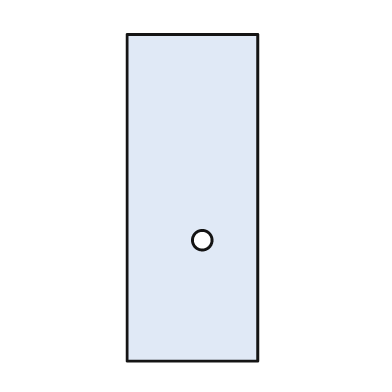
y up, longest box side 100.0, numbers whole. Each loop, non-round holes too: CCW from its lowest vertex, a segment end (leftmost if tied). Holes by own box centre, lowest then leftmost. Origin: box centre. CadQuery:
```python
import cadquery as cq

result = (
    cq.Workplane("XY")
    .moveTo(-20.0, -50.0)
    .lineTo(20.0, -50.0)
    .lineTo(20.0, 50.0)
    .lineTo(-20.0, 50.0)
    .close()
    .moveTo(3.0, -13.0)
    .circle(3.0)
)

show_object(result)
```